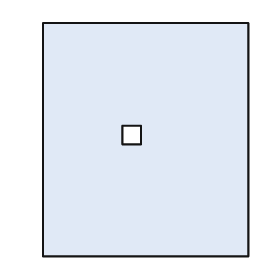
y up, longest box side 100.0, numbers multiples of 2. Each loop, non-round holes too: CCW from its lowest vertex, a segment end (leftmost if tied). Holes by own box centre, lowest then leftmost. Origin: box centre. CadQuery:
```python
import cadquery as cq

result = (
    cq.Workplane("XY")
    .moveTo(-44.0, -50.0)
    .lineTo(44.0, -50.0)
    .lineTo(44.0, 50.0)
    .lineTo(-44.0, 50.0)
    .close()
    .moveTo(-10.0, -2.0)
    .lineTo(-2.0, -2.0)
    .lineTo(-2.0, 6.0)
    .lineTo(-10.0, 6.0)
    .close()
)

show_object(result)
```